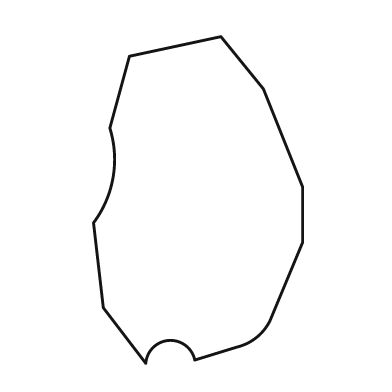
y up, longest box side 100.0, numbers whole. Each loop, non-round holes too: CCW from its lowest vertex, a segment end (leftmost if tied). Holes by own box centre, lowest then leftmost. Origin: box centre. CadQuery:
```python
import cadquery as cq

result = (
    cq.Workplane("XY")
    .moveTo(-16.0, -50.0)
    .threePointArc((-9.0, -43.0), (-1.0, -49.0))
    .lineTo(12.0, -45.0)
    .threePointArc((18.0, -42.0), (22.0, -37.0))
    .lineTo(32.0, -13.0)
    .lineTo(32.0, 4.0)
    .lineTo(20.0, 34.0)
    .lineTo(7.0, 50.0)
    .lineTo(-21.0, 44.0)
    .lineTo(-27.0, 22.0)
    .threePointArc((-26.0, 7.0), (-32.0, -7.0))
    .lineTo(-29.0, -33.0)
    .close()
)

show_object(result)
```